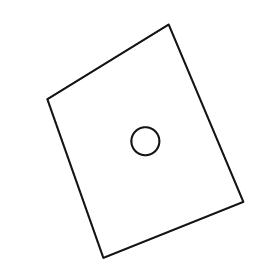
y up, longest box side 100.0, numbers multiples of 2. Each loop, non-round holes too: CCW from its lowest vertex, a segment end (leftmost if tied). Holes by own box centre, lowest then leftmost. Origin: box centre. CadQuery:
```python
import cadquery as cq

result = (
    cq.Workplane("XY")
    .moveTo(-18.0, -50.0)
    .lineTo(42.0, -26.0)
    .lineTo(10.0, 50.0)
    .lineTo(-42.0, 18.0)
    .close()
    .moveTo(0.0, 0.0)
    .circle(6.0)
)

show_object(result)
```